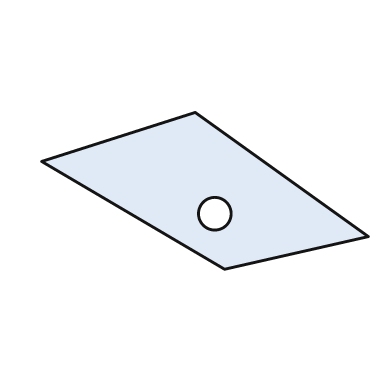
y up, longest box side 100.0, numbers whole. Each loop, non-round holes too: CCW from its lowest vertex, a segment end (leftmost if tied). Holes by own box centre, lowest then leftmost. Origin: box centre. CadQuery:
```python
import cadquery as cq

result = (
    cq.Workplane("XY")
    .moveTo(6.0, -24.0)
    .lineTo(50.0, -14.0)
    .lineTo(-3.0, 24.0)
    .lineTo(-50.0, 9.0)
    .close()
    .moveTo(3.0, -7.0)
    .circle(5.0)
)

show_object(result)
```